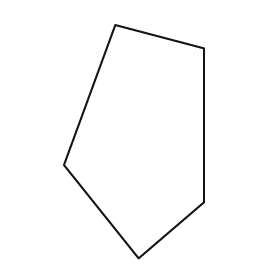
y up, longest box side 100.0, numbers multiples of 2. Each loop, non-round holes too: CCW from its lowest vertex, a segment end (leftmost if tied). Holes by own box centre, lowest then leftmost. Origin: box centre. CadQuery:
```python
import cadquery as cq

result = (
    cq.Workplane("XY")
    .moveTo(2.0, -50.0)
    .lineTo(30.0, -26.0)
    .lineTo(30.0, 40.0)
    .lineTo(-8.0, 50.0)
    .lineTo(-30.0, -10.0)
    .close()
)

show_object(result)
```